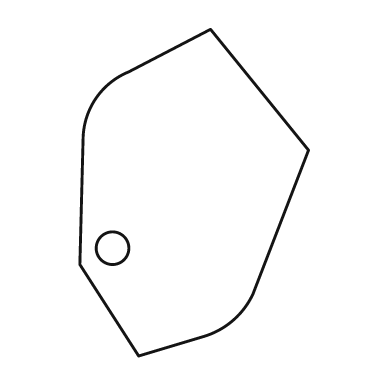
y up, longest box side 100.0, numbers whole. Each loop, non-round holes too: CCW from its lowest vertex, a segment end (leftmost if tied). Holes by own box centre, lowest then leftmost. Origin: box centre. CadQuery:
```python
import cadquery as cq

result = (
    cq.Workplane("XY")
    .moveTo(-17.0, -50.0)
    .lineTo(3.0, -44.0)
    .threePointArc((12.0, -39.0), (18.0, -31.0))
    .lineTo(35.0, 13.0)
    .lineTo(5.0, 50.0)
    .lineTo(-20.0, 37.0)
    .threePointArc((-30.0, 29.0), (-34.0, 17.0))
    .lineTo(-35.0, -22.0)
    .close()
    .moveTo(-25.0, -17.0)
    .circle(5.0)
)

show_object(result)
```